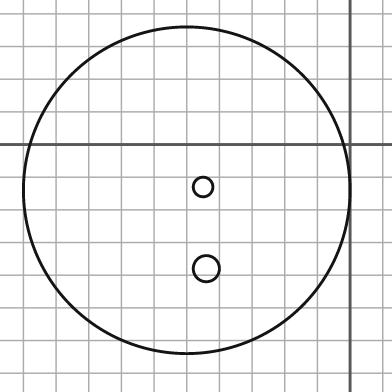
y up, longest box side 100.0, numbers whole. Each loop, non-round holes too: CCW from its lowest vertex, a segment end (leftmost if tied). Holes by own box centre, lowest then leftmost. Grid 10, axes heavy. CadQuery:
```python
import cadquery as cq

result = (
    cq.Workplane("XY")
    .moveTo(-50.0, -14.0)
    .circle(50.0)
    .moveTo(-44.0, -38.0)
    .circle(4.0)
    .moveTo(-45.0, -13.0)
    .circle(3.0)
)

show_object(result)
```